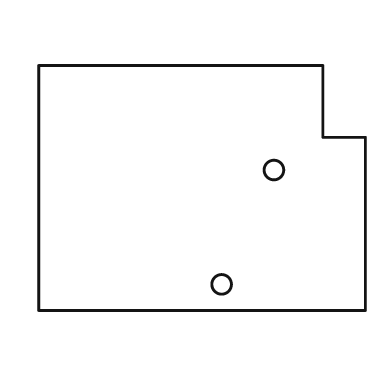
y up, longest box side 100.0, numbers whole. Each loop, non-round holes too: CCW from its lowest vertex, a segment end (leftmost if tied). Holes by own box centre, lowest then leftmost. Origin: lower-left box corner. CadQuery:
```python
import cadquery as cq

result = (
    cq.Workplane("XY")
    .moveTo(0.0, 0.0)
    .lineTo(100.0, 0.0)
    .lineTo(100.0, 53.0)
    .lineTo(87.0, 53.0)
    .lineTo(87.0, 75.0)
    .lineTo(0.0, 75.0)
    .close()
    .moveTo(56.0, 8.0)
    .circle(3.0)
    .moveTo(72.0, 43.0)
    .circle(3.0)
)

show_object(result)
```